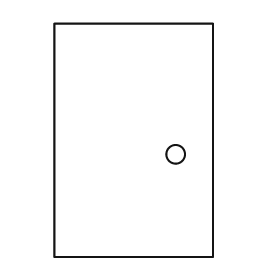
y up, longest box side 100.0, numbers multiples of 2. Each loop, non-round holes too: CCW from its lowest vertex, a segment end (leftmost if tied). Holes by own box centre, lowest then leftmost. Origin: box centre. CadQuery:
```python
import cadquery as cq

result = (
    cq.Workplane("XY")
    .moveTo(-34.0, -50.0)
    .lineTo(34.0, -50.0)
    .lineTo(34.0, 50.0)
    .lineTo(-34.0, 50.0)
    .close()
    .moveTo(18.0, -6.0)
    .circle(4.0)
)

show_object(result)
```